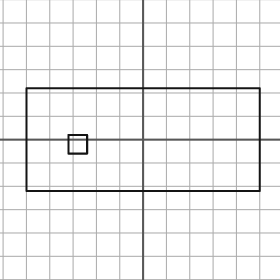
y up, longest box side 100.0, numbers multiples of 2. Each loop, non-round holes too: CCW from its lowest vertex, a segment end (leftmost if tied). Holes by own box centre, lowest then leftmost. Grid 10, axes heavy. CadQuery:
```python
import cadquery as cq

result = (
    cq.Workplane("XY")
    .moveTo(-50.0, -22.0)
    .lineTo(50.0, -22.0)
    .lineTo(50.0, 22.0)
    .lineTo(-50.0, 22.0)
    .close()
    .moveTo(-32.0, -6.0)
    .lineTo(-24.0, -6.0)
    .lineTo(-24.0, 2.0)
    .lineTo(-32.0, 2.0)
    .close()
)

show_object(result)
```